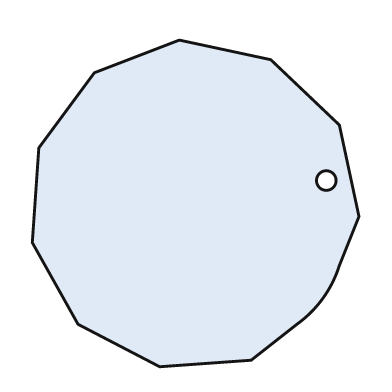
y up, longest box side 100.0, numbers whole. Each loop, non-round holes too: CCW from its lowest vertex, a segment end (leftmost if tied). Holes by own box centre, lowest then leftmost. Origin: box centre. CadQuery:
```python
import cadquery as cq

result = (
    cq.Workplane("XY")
    .moveTo(-11.0, -50.0)
    .lineTo(17.0, -48.0)
    .lineTo(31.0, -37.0)
    .threePointArc((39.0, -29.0), (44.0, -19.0))
    .lineTo(50.0, -4.0)
    .lineTo(44.0, 24.0)
    .lineTo(23.0, 44.0)
    .lineTo(-5.0, 50.0)
    .lineTo(-31.0, 40.0)
    .lineTo(-48.0, 17.0)
    .lineTo(-50.0, -12.0)
    .lineTo(-36.0, -37.0)
    .close()
    .moveTo(40.0, 7.0)
    .circle(3.0)
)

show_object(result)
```